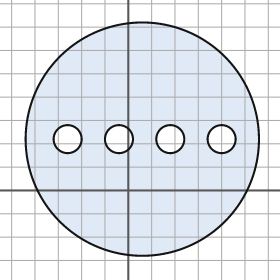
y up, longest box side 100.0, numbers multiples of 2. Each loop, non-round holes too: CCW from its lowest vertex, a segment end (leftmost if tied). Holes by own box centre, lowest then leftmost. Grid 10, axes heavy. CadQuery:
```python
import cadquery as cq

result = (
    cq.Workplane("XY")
    .moveTo(6.0, 22.0)
    .circle(50.0)
    .moveTo(-26.0, 22.0)
    .circle(6.0)
    .moveTo(-4.0, 22.0)
    .circle(6.0)
    .moveTo(18.0, 22.0)
    .circle(6.0)
    .moveTo(40.0, 22.0)
    .circle(6.0)
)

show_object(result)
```